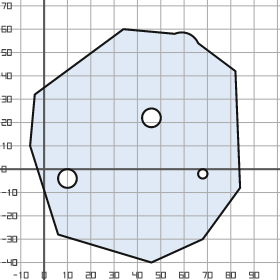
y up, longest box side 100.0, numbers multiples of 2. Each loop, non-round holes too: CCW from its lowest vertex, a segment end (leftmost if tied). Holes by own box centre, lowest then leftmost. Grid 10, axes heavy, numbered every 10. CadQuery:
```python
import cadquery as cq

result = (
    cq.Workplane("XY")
    .moveTo(46.0, -40.0)
    .lineTo(68.0, -30.0)
    .lineTo(84.0, -8.0)
    .lineTo(82.0, 42.0)
    .lineTo(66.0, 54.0)
    .threePointArc((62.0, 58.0), (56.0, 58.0))
    .lineTo(34.0, 60.0)
    .lineTo(-4.0, 32.0)
    .lineTo(-6.0, 10.0)
    .lineTo(6.0, -28.0)
    .close()
    .moveTo(10.0, -4.0)
    .circle(4.0)
    .moveTo(68.0, -2.0)
    .circle(2.0)
    .moveTo(46.0, 22.0)
    .circle(4.0)
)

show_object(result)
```